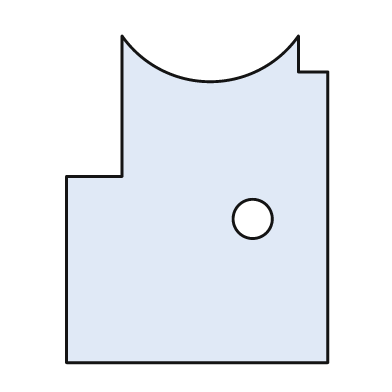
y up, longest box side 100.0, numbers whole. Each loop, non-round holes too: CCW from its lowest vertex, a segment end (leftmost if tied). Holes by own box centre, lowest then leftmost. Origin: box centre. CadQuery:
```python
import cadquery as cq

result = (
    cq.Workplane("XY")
    .moveTo(-40.0, -50.0)
    .lineTo(40.0, -50.0)
    .lineTo(40.0, 39.0)
    .lineTo(31.0, 39.0)
    .lineTo(31.0, 50.0)
    .threePointArc((4.0, 36.0), (-23.0, 50.0))
    .lineTo(-23.0, 7.0)
    .lineTo(-40.0, 7.0)
    .close()
    .moveTo(17.0, -6.0)
    .circle(6.0)
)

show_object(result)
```